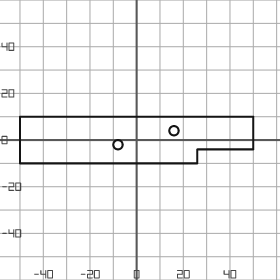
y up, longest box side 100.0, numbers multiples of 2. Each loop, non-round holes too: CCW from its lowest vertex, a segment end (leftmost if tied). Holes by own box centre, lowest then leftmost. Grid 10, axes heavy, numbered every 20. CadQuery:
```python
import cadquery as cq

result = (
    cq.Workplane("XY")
    .moveTo(-50.0, -10.0)
    .lineTo(26.0, -10.0)
    .lineTo(26.0, -4.0)
    .lineTo(50.0, -4.0)
    .lineTo(50.0, 10.0)
    .lineTo(-50.0, 10.0)
    .close()
    .moveTo(-8.0, -2.0)
    .circle(2.0)
    .moveTo(16.0, 4.0)
    .circle(2.0)
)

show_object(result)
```